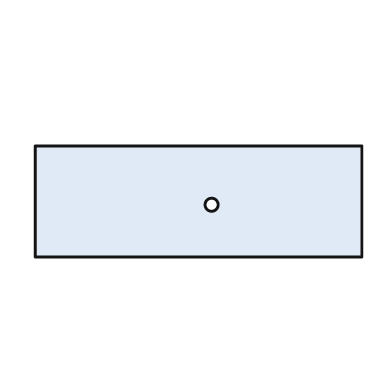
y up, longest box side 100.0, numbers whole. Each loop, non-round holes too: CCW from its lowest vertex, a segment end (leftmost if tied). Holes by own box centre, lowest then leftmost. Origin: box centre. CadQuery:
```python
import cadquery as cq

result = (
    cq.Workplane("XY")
    .moveTo(-50.0, -17.0)
    .lineTo(50.0, -17.0)
    .lineTo(50.0, 17.0)
    .lineTo(-50.0, 17.0)
    .close()
    .moveTo(4.0, -1.0)
    .circle(2.0)
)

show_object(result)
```